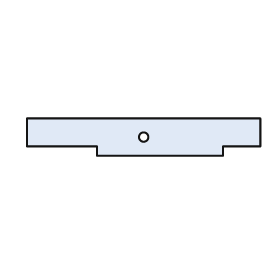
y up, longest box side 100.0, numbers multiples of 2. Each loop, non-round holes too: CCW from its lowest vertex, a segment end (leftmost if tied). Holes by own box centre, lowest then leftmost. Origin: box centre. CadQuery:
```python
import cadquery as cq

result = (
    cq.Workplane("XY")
    .moveTo(-20.0, -8.0)
    .lineTo(34.0, -8.0)
    .lineTo(34.0, -4.0)
    .lineTo(50.0, -4.0)
    .lineTo(50.0, 8.0)
    .lineTo(-50.0, 8.0)
    .lineTo(-50.0, -4.0)
    .lineTo(-20.0, -4.0)
    .close()
    .moveTo(0.0, 0.0)
    .circle(2.0)
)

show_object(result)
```